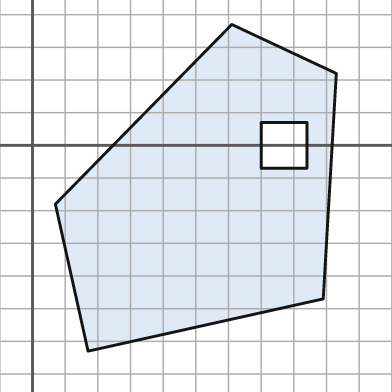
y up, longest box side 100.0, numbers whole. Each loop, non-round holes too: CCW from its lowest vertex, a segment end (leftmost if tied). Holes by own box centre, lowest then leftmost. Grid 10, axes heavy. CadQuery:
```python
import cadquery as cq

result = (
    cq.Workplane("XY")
    .moveTo(17.0, -63.0)
    .lineTo(89.0, -47.0)
    .lineTo(93.0, 22.0)
    .lineTo(61.0, 37.0)
    .lineTo(7.0, -18.0)
    .close()
    .moveTo(70.0, -7.0)
    .lineTo(84.0, -7.0)
    .lineTo(84.0, 7.0)
    .lineTo(70.0, 7.0)
    .close()
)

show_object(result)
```